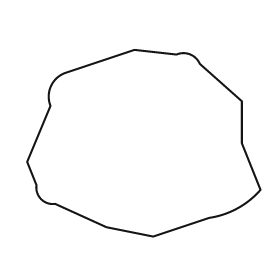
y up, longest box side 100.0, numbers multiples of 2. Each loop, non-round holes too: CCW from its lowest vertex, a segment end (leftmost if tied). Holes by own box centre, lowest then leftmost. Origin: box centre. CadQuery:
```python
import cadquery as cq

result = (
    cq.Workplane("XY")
    .moveTo(4.0, -40.0)
    .lineTo(28.0, -32.0)
    .threePointArc((40.0, -28.0), (50.0, -20.0))
    .lineTo(42.0, 0.0)
    .lineTo(42.0, 18.0)
    .lineTo(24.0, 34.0)
    .threePointArc((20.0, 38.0), (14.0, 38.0))
    .lineTo(-4.0, 40.0)
    .lineTo(-34.0, 30.0)
    .threePointArc((-40.0, 24.0), (-40.0, 16.0))
    .lineTo(-50.0, -8.0)
    .lineTo(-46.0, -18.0)
    .threePointArc((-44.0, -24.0), (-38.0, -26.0))
    .lineTo(-16.0, -36.0)
    .close()
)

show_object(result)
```